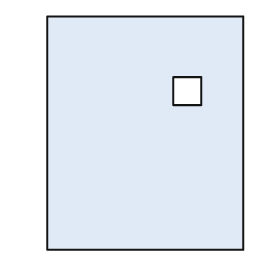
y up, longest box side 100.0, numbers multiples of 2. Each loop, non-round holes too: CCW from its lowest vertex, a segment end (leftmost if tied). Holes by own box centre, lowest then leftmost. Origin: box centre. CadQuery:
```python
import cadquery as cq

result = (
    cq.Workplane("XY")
    .moveTo(-42.0, -50.0)
    .lineTo(42.0, -50.0)
    .lineTo(42.0, 50.0)
    .lineTo(-42.0, 50.0)
    .close()
    .moveTo(12.0, 12.0)
    .lineTo(24.0, 12.0)
    .lineTo(24.0, 24.0)
    .lineTo(12.0, 24.0)
    .close()
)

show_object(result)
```